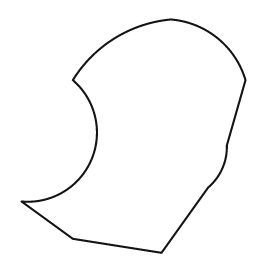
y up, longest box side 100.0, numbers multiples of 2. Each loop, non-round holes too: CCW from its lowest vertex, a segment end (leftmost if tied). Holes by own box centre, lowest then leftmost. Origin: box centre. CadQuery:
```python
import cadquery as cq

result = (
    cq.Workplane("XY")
    .moveTo(12.0, -50.0)
    .lineTo(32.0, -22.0)
    .threePointArc((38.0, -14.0), (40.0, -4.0))
    .lineTo(48.0, 24.0)
    .threePointArc((36.0, 42.0), (16.0, 50.0))
    .threePointArc((-8.0, 42.0), (-26.0, 24.0))
    .threePointArc((-18.0, -10.0), (-48.0, -28.0))
    .lineTo(-26.0, -44.0)
    .close()
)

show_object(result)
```